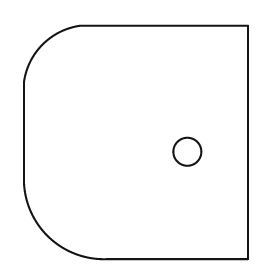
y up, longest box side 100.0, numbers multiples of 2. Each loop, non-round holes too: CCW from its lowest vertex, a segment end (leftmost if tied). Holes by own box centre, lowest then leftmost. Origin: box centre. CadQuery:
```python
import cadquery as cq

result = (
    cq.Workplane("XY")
    .moveTo(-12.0, -50.0)
    .lineTo(48.0, -50.0)
    .lineTo(48.0, 50.0)
    .lineTo(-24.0, 50.0)
    .threePointArc((-40.0, 42.0), (-48.0, 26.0))
    .lineTo(-48.0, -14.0)
    .threePointArc((-38.0, -40.0), (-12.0, -50.0))
    .close()
    .moveTo(22.0, -4.0)
    .circle(6.0)
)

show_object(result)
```